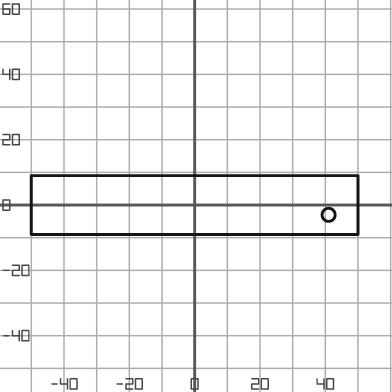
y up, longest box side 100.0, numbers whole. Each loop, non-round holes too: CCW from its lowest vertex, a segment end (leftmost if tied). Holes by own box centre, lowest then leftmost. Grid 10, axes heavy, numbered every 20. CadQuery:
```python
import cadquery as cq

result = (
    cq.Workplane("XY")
    .moveTo(-50.0, -9.0)
    .lineTo(50.0, -9.0)
    .lineTo(50.0, 9.0)
    .lineTo(-50.0, 9.0)
    .close()
    .moveTo(41.0, -3.0)
    .circle(2.0)
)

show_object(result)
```